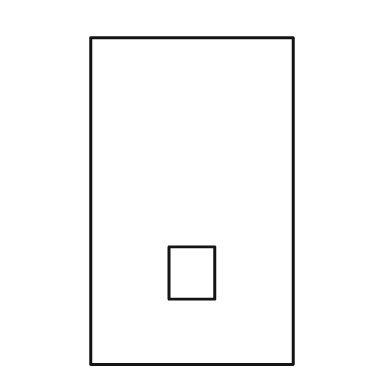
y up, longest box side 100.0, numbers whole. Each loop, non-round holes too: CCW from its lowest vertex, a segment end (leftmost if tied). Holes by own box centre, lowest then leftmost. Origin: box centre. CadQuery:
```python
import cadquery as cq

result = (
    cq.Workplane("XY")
    .moveTo(-31.0, -50.0)
    .lineTo(31.0, -50.0)
    .lineTo(31.0, 50.0)
    .lineTo(-31.0, 50.0)
    .close()
    .moveTo(-7.0, -30.0)
    .lineTo(7.0, -30.0)
    .lineTo(7.0, -14.0)
    .lineTo(-7.0, -14.0)
    .close()
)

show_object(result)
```